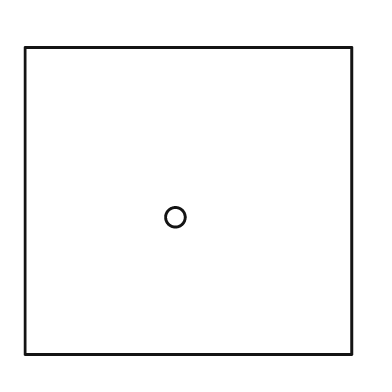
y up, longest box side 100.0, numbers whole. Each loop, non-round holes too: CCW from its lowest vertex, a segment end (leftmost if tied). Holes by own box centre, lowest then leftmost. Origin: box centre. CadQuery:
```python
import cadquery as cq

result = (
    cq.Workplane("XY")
    .moveTo(-50.0, -47.0)
    .lineTo(50.0, -47.0)
    .lineTo(50.0, 47.0)
    .lineTo(-50.0, 47.0)
    .close()
    .moveTo(-4.0, -5.0)
    .circle(3.0)
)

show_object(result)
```